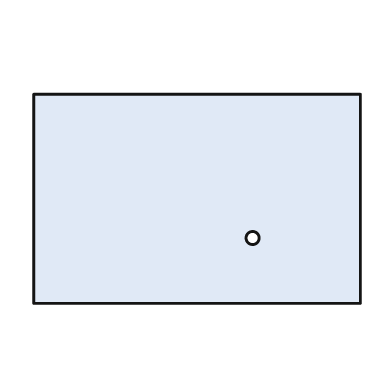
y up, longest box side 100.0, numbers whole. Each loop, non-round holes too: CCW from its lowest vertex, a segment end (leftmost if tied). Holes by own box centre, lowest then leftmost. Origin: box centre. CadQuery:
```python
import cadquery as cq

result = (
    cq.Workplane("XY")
    .moveTo(-50.0, -32.0)
    .lineTo(50.0, -32.0)
    .lineTo(50.0, 32.0)
    .lineTo(-50.0, 32.0)
    .close()
    .moveTo(17.0, -12.0)
    .circle(2.0)
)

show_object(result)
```